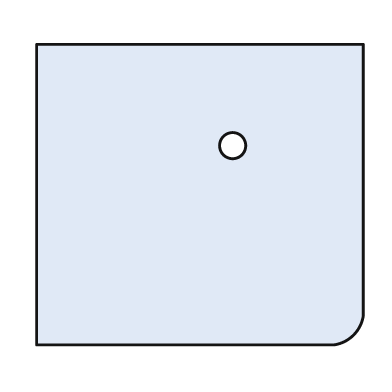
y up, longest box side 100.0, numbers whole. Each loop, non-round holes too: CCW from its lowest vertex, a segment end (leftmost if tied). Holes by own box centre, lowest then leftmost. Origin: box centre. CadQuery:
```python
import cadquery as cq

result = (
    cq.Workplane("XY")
    .moveTo(-50.0, -46.0)
    .lineTo(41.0, -46.0)
    .threePointArc((47.0, -43.0), (50.0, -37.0))
    .lineTo(50.0, 46.0)
    .lineTo(-50.0, 46.0)
    .close()
    .moveTo(10.0, 15.0)
    .circle(4.0)
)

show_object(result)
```